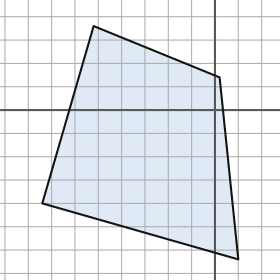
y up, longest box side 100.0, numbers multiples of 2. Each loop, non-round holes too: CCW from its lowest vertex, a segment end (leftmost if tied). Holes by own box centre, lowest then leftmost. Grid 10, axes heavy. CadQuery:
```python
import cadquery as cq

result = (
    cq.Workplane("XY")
    .moveTo(10.0, -64.0)
    .lineTo(2.0, 14.0)
    .lineTo(-52.0, 36.0)
    .lineTo(-74.0, -40.0)
    .close()
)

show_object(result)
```